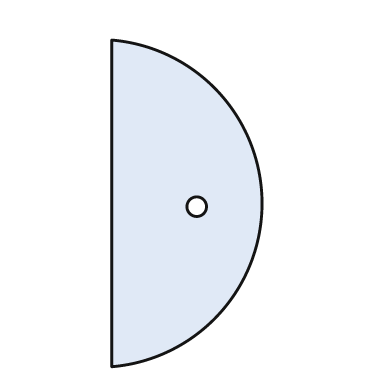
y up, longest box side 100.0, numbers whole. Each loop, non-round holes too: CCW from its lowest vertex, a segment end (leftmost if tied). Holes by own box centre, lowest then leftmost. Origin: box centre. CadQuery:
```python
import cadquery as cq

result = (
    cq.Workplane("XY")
    .moveTo(-23.0, -50.0)
    .threePointArc((23.0, 0.0), (-23.0, 50.0))
    .close()
    .moveTo(3.0, -1.0)
    .circle(3.0)
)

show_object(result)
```